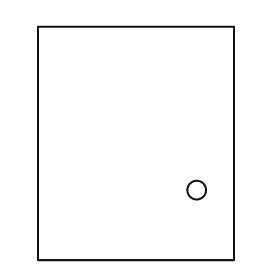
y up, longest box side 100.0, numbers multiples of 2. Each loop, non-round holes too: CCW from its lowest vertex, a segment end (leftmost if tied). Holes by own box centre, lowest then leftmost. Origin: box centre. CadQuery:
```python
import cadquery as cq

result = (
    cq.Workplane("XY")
    .moveTo(-42.0, -50.0)
    .lineTo(42.0, -50.0)
    .lineTo(42.0, 50.0)
    .lineTo(-42.0, 50.0)
    .close()
    .moveTo(26.0, -20.0)
    .circle(4.0)
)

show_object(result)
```